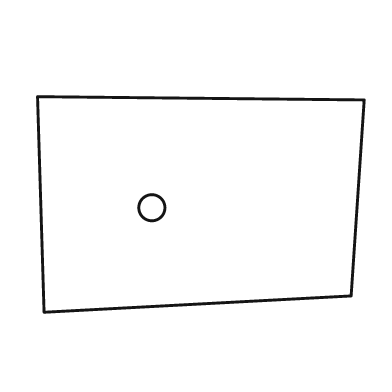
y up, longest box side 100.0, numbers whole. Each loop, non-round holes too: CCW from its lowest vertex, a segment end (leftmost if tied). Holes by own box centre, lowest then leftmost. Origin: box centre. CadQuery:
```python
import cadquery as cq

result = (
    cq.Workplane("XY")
    .moveTo(-48.0, -33.0)
    .lineTo(46.0, -28.0)
    .lineTo(50.0, 32.0)
    .lineTo(-50.0, 33.0)
    .close()
    .moveTo(-15.0, -1.0)
    .circle(4.0)
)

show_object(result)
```